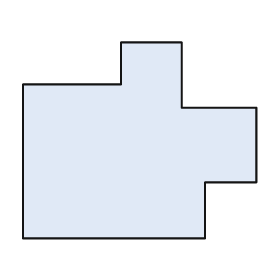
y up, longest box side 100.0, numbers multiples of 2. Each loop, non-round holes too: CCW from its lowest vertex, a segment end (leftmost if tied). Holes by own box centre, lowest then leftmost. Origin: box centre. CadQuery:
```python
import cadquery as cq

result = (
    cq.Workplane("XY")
    .moveTo(-50.0, -42.0)
    .lineTo(28.0, -42.0)
    .lineTo(28.0, -18.0)
    .lineTo(50.0, -18.0)
    .lineTo(50.0, 14.0)
    .lineTo(18.0, 14.0)
    .lineTo(18.0, 42.0)
    .lineTo(-8.0, 42.0)
    .lineTo(-8.0, 24.0)
    .lineTo(-50.0, 24.0)
    .close()
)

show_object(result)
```